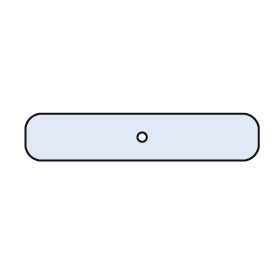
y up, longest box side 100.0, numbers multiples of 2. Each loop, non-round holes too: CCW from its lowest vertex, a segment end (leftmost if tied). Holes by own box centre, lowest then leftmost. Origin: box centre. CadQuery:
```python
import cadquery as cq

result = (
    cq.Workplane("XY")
    .moveTo(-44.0, -10.0)
    .lineTo(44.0, -10.0)
    .threePointArc((48.0, -8.0), (50.0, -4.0))
    .lineTo(50.0, 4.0)
    .threePointArc((48.0, 8.0), (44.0, 10.0))
    .lineTo(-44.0, 10.0)
    .threePointArc((-48.0, 8.0), (-50.0, 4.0))
    .lineTo(-50.0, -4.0)
    .threePointArc((-48.0, -8.0), (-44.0, -10.0))
    .close()
    .moveTo(0.0, 0.0)
    .circle(2.0)
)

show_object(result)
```